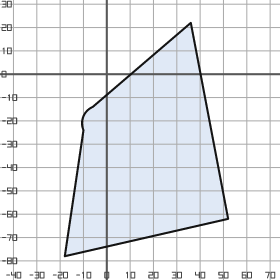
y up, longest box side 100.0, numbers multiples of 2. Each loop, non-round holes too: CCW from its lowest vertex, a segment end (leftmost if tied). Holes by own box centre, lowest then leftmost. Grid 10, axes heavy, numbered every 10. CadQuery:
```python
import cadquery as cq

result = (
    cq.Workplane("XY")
    .moveTo(-18.0, -78.0)
    .lineTo(52.0, -62.0)
    .lineTo(36.0, 22.0)
    .lineTo(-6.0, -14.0)
    .threePointArc((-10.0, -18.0), (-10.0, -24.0))
    .close()
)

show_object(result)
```